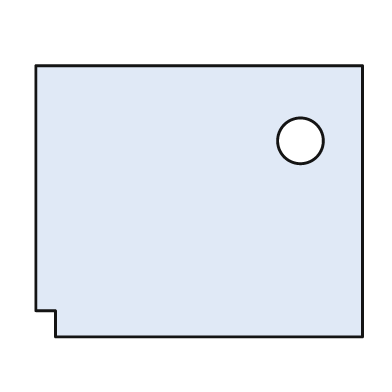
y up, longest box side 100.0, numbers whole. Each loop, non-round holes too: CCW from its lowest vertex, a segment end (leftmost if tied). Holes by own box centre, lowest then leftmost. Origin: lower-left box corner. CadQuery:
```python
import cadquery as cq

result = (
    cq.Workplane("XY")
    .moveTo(6.0, 0.0)
    .lineTo(100.0, 0.0)
    .lineTo(100.0, 83.0)
    .lineTo(0.0, 83.0)
    .lineTo(0.0, 8.0)
    .lineTo(6.0, 8.0)
    .close()
    .moveTo(81.0, 60.0)
    .circle(7.0)
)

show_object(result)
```